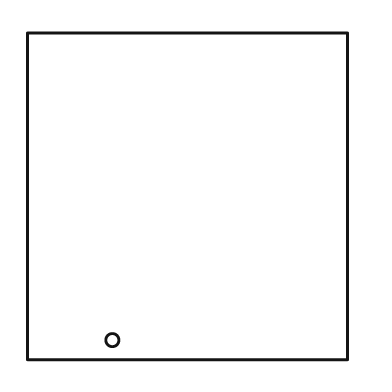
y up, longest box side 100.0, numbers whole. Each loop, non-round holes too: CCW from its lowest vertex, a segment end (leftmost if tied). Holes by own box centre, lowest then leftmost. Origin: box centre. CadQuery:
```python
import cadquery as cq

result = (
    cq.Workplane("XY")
    .moveTo(-49.0, -50.0)
    .lineTo(49.0, -50.0)
    .lineTo(49.0, 50.0)
    .lineTo(-49.0, 50.0)
    .close()
    .moveTo(-23.0, -44.0)
    .circle(2.0)
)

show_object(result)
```